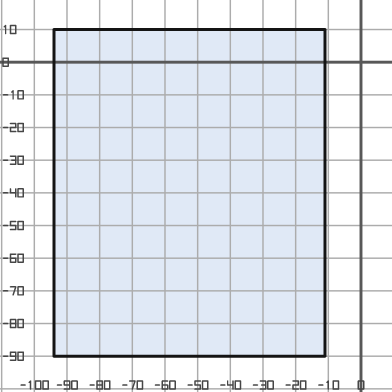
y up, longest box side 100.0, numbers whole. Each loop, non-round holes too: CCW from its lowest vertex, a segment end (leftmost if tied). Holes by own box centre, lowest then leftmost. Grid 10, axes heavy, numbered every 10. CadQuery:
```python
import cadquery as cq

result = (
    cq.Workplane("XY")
    .moveTo(-94.0, -90.0)
    .lineTo(-11.0, -90.0)
    .lineTo(-11.0, 10.0)
    .lineTo(-94.0, 10.0)
    .close()
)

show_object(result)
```